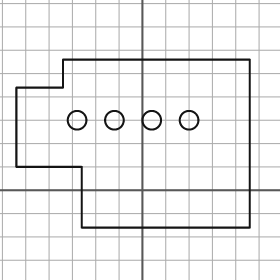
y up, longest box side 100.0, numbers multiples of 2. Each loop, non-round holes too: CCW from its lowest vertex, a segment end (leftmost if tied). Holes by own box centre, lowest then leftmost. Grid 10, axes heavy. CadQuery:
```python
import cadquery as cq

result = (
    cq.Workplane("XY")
    .moveTo(-26.0, -16.0)
    .lineTo(46.0, -16.0)
    .lineTo(46.0, 56.0)
    .lineTo(-34.0, 56.0)
    .lineTo(-34.0, 44.0)
    .lineTo(-54.0, 44.0)
    .lineTo(-54.0, 10.0)
    .lineTo(-26.0, 10.0)
    .close()
    .moveTo(-28.0, 30.0)
    .circle(4.0)
    .moveTo(-12.0, 30.0)
    .circle(4.0)
    .moveTo(4.0, 30.0)
    .circle(4.0)
    .moveTo(20.0, 30.0)
    .circle(4.0)
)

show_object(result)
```